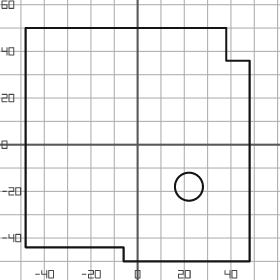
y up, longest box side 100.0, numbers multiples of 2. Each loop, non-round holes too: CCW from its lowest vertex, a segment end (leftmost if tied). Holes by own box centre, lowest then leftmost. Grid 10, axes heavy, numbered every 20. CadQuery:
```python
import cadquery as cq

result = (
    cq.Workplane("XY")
    .moveTo(-6.0, -50.0)
    .lineTo(48.0, -50.0)
    .lineTo(48.0, 36.0)
    .lineTo(38.0, 36.0)
    .lineTo(38.0, 50.0)
    .lineTo(-48.0, 50.0)
    .lineTo(-48.0, -44.0)
    .lineTo(-6.0, -44.0)
    .close()
    .moveTo(22.0, -18.0)
    .circle(6.0)
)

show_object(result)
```